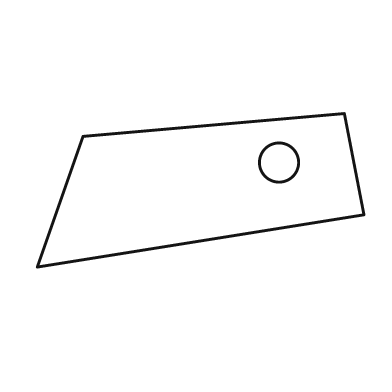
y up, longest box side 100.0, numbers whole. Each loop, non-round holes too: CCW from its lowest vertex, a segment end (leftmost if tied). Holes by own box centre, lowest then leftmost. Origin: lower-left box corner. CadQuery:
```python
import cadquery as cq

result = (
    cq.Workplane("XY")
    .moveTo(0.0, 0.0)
    .lineTo(100.0, 16.0)
    .lineTo(94.0, 47.0)
    .lineTo(14.0, 40.0)
    .close()
    .moveTo(74.0, 32.0)
    .circle(6.0)
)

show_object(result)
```